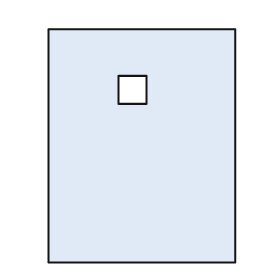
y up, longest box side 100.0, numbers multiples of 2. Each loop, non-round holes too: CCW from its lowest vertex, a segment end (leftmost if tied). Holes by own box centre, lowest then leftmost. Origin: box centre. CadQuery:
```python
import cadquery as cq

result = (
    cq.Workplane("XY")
    .moveTo(-40.0, -50.0)
    .lineTo(40.0, -50.0)
    .lineTo(40.0, 50.0)
    .lineTo(-40.0, 50.0)
    .close()
    .moveTo(-10.0, 18.0)
    .lineTo(2.0, 18.0)
    .lineTo(2.0, 30.0)
    .lineTo(-10.0, 30.0)
    .close()
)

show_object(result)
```